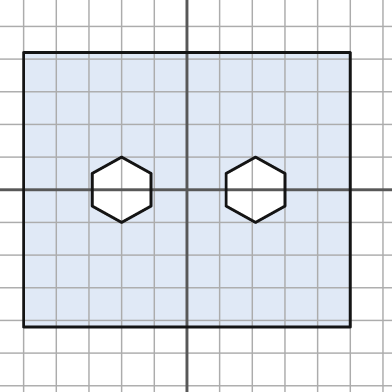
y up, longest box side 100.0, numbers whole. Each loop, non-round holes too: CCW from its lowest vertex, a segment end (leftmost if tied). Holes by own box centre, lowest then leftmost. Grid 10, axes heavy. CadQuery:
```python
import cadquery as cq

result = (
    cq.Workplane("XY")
    .moveTo(-50.0, -42.0)
    .lineTo(50.0, -42.0)
    .lineTo(50.0, 42.0)
    .lineTo(-50.0, 42.0)
    .close()
    .moveTo(-20.0, -10.0)
    .lineTo(-11.0, -5.0)
    .lineTo(-11.0, 5.0)
    .lineTo(-20.0, 10.0)
    .lineTo(-29.0, 5.0)
    .lineTo(-29.0, -5.0)
    .close()
    .moveTo(21.0, -10.0)
    .lineTo(30.0, -5.0)
    .lineTo(30.0, 5.0)
    .lineTo(21.0, 10.0)
    .lineTo(12.0, 5.0)
    .lineTo(12.0, -5.0)
    .close()
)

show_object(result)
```